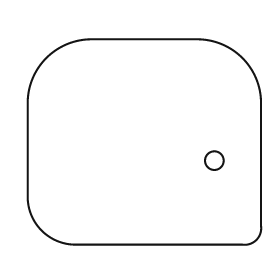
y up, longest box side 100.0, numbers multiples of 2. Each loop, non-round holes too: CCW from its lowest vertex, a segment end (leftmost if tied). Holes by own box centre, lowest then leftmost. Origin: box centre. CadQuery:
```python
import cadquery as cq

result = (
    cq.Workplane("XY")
    .moveTo(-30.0, -44.0)
    .lineTo(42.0, -44.0)
    .threePointArc((48.0, -42.0), (50.0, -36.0))
    .lineTo(50.0, 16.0)
    .threePointArc((42.0, 36.0), (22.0, 44.0))
    .lineTo(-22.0, 44.0)
    .threePointArc((-42.0, 36.0), (-50.0, 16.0))
    .lineTo(-50.0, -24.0)
    .threePointArc((-44.0, -38.0), (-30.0, -44.0))
    .close()
    .moveTo(30.0, -8.0)
    .circle(4.0)
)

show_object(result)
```